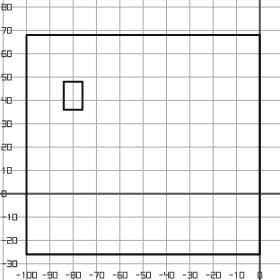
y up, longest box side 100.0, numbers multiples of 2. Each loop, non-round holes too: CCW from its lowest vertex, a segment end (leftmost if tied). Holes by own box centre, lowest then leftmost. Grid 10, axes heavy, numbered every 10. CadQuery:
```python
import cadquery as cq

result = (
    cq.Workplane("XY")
    .moveTo(-100.0, -26.0)
    .lineTo(0.0, -26.0)
    .lineTo(0.0, 68.0)
    .lineTo(-100.0, 68.0)
    .close()
    .moveTo(-84.0, 36.0)
    .lineTo(-76.0, 36.0)
    .lineTo(-76.0, 48.0)
    .lineTo(-84.0, 48.0)
    .close()
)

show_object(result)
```